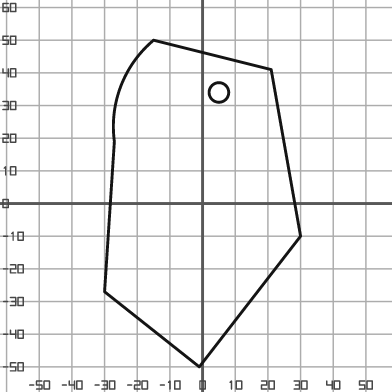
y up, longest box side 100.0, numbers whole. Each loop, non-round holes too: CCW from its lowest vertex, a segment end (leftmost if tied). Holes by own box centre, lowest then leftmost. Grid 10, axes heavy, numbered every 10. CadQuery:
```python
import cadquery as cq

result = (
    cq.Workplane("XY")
    .moveTo(-1.0, -50.0)
    .lineTo(30.0, -10.0)
    .lineTo(21.0, 41.0)
    .lineTo(-15.0, 50.0)
    .threePointArc((-25.0, 36.0), (-27.0, 19.0))
    .lineTo(-30.0, -27.0)
    .close()
    .moveTo(5.0, 34.0)
    .circle(3.0)
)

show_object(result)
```